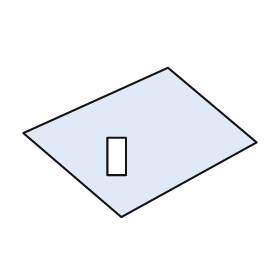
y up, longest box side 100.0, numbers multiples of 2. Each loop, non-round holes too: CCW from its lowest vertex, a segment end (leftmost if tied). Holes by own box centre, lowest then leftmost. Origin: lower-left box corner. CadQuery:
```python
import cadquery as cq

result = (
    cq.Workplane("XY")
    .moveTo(42.0, 0.0)
    .lineTo(100.0, 32.0)
    .lineTo(62.0, 64.0)
    .lineTo(0.0, 36.0)
    .close()
    .moveTo(36.0, 18.0)
    .lineTo(44.0, 18.0)
    .lineTo(44.0, 34.0)
    .lineTo(36.0, 34.0)
    .close()
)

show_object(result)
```